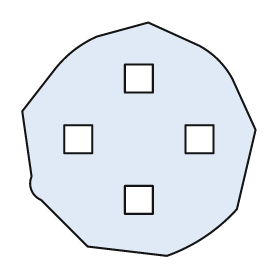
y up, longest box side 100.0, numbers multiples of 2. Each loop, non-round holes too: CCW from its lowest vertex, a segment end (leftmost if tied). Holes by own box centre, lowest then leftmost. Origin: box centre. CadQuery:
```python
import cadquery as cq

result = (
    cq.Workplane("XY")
    .moveTo(12.0, -50.0)
    .threePointArc((28.0, -42.0), (42.0, -30.0))
    .lineTo(50.0, 4.0)
    .lineTo(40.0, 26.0)
    .threePointArc((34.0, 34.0), (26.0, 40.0))
    .lineTo(4.0, 50.0)
    .lineTo(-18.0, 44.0)
    .threePointArc((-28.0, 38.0), (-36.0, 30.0))
    .lineTo(-50.0, 12.0)
    .lineTo(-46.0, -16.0)
    .threePointArc((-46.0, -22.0), (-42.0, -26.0))
    .lineTo(-22.0, -46.0)
    .close()
    .moveTo(-6.0, -32.0)
    .lineTo(6.0, -32.0)
    .lineTo(6.0, -20.0)
    .lineTo(-6.0, -20.0)
    .close()
    .moveTo(-32.0, -6.0)
    .lineTo(-20.0, -6.0)
    .lineTo(-20.0, 6.0)
    .lineTo(-32.0, 6.0)
    .close()
    .moveTo(20.0, -6.0)
    .lineTo(32.0, -6.0)
    .lineTo(32.0, 6.0)
    .lineTo(20.0, 6.0)
    .close()
    .moveTo(-6.0, 20.0)
    .lineTo(6.0, 20.0)
    .lineTo(6.0, 32.0)
    .lineTo(-6.0, 32.0)
    .close()
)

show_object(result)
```